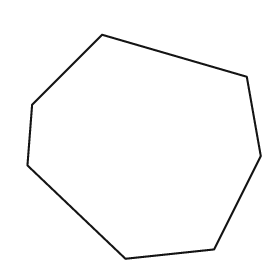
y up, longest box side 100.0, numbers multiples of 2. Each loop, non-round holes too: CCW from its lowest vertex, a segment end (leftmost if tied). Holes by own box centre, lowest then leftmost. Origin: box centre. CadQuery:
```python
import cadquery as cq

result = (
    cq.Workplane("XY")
    .moveTo(-8.0, -48.0)
    .lineTo(30.0, -44.0)
    .lineTo(50.0, -4.0)
    .lineTo(44.0, 30.0)
    .lineTo(-18.0, 48.0)
    .lineTo(-48.0, 18.0)
    .lineTo(-50.0, -8.0)
    .close()
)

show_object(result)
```